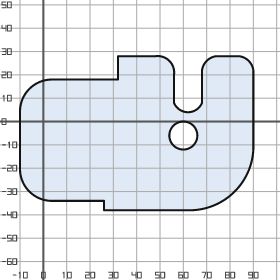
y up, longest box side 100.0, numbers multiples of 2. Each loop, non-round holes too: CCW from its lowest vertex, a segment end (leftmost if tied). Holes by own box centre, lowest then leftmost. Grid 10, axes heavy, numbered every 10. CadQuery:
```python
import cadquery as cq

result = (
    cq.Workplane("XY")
    .moveTo(26.0, -38.0)
    .lineTo(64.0, -38.0)
    .threePointArc((82.0, -30.0), (90.0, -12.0))
    .lineTo(90.0, 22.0)
    .threePointArc((88.0, 26.0), (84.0, 28.0))
    .lineTo(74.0, 28.0)
    .threePointArc((70.0, 26.0), (68.0, 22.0))
    .lineTo(68.0, 8.0)
    .threePointArc((62.0, 4.0), (56.0, 8.0))
    .lineTo(56.0, 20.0)
    .threePointArc((54.0, 26.0), (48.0, 28.0))
    .lineTo(32.0, 28.0)
    .lineTo(32.0, 18.0)
    .lineTo(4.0, 18.0)
    .threePointArc((-6.0, 14.0), (-10.0, 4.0))
    .lineTo(-10.0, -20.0)
    .threePointArc((-6.0, -30.0), (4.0, -34.0))
    .lineTo(26.0, -34.0)
    .close()
    .moveTo(60.0, -6.0)
    .circle(6.0)
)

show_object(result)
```